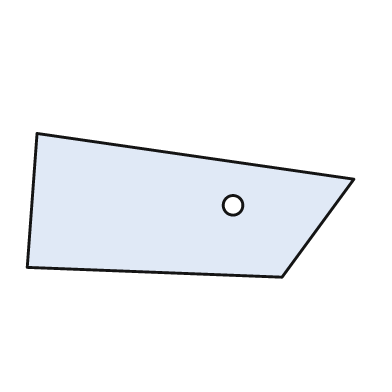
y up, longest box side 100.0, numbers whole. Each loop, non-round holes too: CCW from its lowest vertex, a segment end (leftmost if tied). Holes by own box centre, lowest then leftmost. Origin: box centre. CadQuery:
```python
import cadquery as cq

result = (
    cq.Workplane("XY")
    .moveTo(28.0, -22.0)
    .lineTo(50.0, 8.0)
    .lineTo(-47.0, 22.0)
    .lineTo(-50.0, -19.0)
    .close()
    .moveTo(13.0, 0.0)
    .circle(3.0)
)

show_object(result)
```